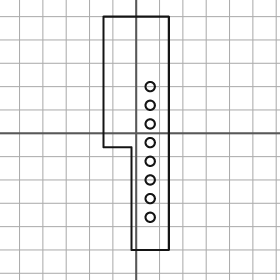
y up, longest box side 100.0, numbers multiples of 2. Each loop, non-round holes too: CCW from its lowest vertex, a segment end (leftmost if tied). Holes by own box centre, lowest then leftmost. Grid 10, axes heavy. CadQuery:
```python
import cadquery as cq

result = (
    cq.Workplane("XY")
    .moveTo(-2.0, -50.0)
    .lineTo(14.0, -50.0)
    .lineTo(14.0, 50.0)
    .lineTo(-14.0, 50.0)
    .lineTo(-14.0, -6.0)
    .lineTo(-2.0, -6.0)
    .close()
    .moveTo(6.0, -36.0)
    .circle(2.0)
    .moveTo(6.0, -28.0)
    .circle(2.0)
    .moveTo(6.0, -20.0)
    .circle(2.0)
    .moveTo(6.0, -12.0)
    .circle(2.0)
    .moveTo(6.0, -4.0)
    .circle(2.0)
    .moveTo(6.0, 4.0)
    .circle(2.0)
    .moveTo(6.0, 12.0)
    .circle(2.0)
    .moveTo(6.0, 20.0)
    .circle(2.0)
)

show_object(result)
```